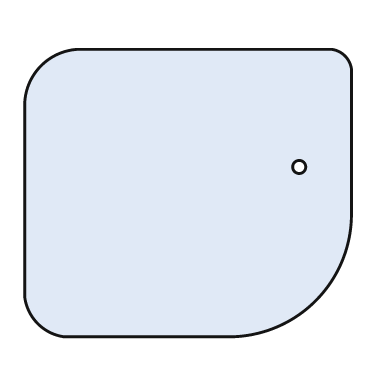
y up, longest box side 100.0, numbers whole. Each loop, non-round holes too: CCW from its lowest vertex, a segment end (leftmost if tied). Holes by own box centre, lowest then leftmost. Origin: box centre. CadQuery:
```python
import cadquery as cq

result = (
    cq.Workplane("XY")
    .moveTo(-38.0, -44.0)
    .lineTo(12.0, -44.0)
    .threePointArc((39.0, -33.0), (50.0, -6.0))
    .lineTo(50.0, 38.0)
    .threePointArc((48.0, 42.0), (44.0, 44.0))
    .lineTo(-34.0, 44.0)
    .threePointArc((-45.0, 39.0), (-50.0, 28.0))
    .lineTo(-50.0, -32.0)
    .threePointArc((-46.0, -40.0), (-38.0, -44.0))
    .close()
    .moveTo(34.0, 8.0)
    .circle(2.0)
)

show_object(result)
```